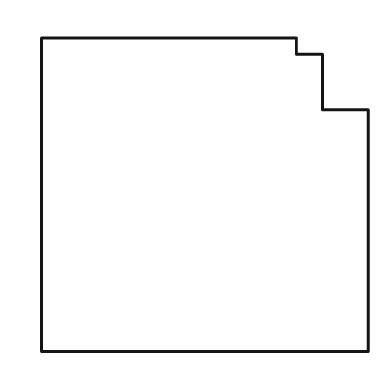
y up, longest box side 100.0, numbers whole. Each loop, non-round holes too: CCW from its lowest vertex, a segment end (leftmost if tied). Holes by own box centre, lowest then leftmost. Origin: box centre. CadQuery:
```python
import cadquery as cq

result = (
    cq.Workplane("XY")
    .moveTo(-50.0, -48.0)
    .lineTo(50.0, -48.0)
    .lineTo(50.0, 26.0)
    .lineTo(36.0, 26.0)
    .lineTo(36.0, 43.0)
    .lineTo(28.0, 43.0)
    .lineTo(28.0, 48.0)
    .lineTo(-50.0, 48.0)
    .close()
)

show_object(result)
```